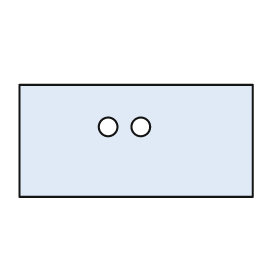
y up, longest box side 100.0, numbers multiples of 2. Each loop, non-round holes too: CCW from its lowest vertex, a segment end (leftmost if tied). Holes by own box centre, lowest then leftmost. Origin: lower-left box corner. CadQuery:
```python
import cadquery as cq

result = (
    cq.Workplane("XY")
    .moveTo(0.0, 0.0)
    .lineTo(100.0, 0.0)
    .lineTo(100.0, 48.0)
    .lineTo(0.0, 48.0)
    .close()
    .moveTo(38.0, 30.0)
    .circle(4.0)
    .moveTo(52.0, 30.0)
    .circle(4.0)
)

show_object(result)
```